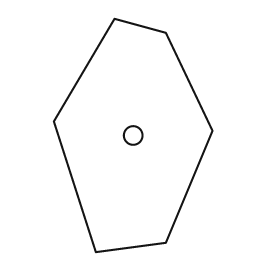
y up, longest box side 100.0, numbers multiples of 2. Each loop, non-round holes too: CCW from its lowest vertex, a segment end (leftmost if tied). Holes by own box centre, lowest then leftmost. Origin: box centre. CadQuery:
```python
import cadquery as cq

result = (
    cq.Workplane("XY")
    .moveTo(-16.0, -50.0)
    .lineTo(14.0, -46.0)
    .lineTo(34.0, 2.0)
    .lineTo(14.0, 44.0)
    .lineTo(-8.0, 50.0)
    .lineTo(-34.0, 6.0)
    .close()
    .moveTo(0.0, 0.0)
    .circle(4.0)
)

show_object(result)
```